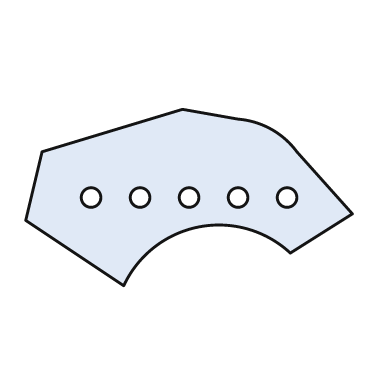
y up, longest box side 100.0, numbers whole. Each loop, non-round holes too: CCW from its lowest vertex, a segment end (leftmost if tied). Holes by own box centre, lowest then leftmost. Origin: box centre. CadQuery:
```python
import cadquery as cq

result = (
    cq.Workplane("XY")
    .moveTo(-20.0, -27.0)
    .threePointArc((3.0, -9.0), (31.0, -17.0))
    .lineTo(50.0, -5.0)
    .lineTo(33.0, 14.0)
    .threePointArc((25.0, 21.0), (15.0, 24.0))
    .lineTo(-2.0, 27.0)
    .lineTo(-45.0, 14.0)
    .lineTo(-50.0, -7.0)
    .close()
    .moveTo(-30.0, 0.0)
    .circle(3.0)
    .moveTo(-15.0, 0.0)
    .circle(3.0)
    .moveTo(0.0, 0.0)
    .circle(3.0)
    .moveTo(15.0, 0.0)
    .circle(3.0)
    .moveTo(30.0, 0.0)
    .circle(3.0)
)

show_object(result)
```